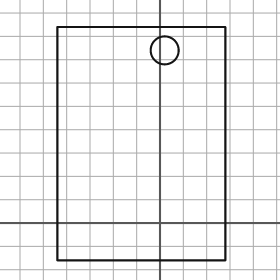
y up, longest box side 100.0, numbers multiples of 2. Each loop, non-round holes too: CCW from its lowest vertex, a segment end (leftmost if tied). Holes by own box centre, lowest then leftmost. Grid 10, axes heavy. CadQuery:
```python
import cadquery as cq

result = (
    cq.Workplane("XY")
    .moveTo(-44.0, -16.0)
    .lineTo(28.0, -16.0)
    .lineTo(28.0, 84.0)
    .lineTo(-44.0, 84.0)
    .close()
    .moveTo(2.0, 74.0)
    .circle(6.0)
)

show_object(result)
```